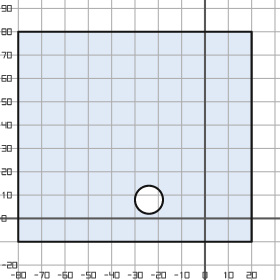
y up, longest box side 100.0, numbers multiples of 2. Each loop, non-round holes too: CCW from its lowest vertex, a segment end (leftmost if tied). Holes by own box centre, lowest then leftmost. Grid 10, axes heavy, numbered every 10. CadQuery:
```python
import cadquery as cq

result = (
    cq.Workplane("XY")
    .moveTo(-80.0, -10.0)
    .lineTo(20.0, -10.0)
    .lineTo(20.0, 80.0)
    .lineTo(-80.0, 80.0)
    .close()
    .moveTo(-24.0, 8.0)
    .circle(6.0)
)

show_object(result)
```